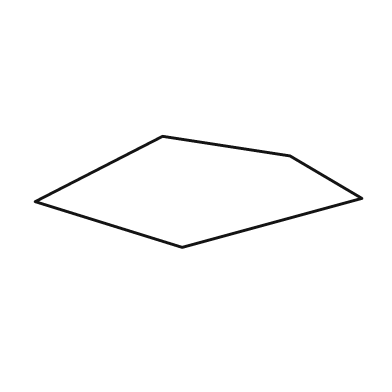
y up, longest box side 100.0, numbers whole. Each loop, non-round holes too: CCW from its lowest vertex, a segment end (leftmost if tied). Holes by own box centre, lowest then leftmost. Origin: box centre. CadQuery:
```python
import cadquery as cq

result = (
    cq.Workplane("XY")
    .moveTo(-5.0, -17.0)
    .lineTo(50.0, -2.0)
    .lineTo(28.0, 11.0)
    .lineTo(-11.0, 17.0)
    .lineTo(-50.0, -3.0)
    .close()
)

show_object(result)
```